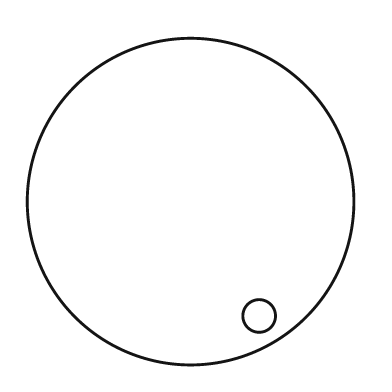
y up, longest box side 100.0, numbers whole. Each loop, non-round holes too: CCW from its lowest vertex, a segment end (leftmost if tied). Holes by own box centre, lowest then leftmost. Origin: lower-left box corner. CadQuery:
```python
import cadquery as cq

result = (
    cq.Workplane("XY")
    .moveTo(50.0, 50.0)
    .circle(50.0)
    .moveTo(71.0, 15.0)
    .circle(5.0)
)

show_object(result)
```